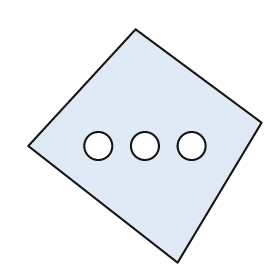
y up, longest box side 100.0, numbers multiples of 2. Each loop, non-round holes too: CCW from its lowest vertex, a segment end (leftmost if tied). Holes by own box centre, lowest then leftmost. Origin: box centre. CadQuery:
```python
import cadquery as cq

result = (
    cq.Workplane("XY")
    .moveTo(14.0, -50.0)
    .lineTo(50.0, 10.0)
    .lineTo(-4.0, 50.0)
    .lineTo(-50.0, 0.0)
    .close()
    .moveTo(-20.0, 0.0)
    .circle(6.0)
    .moveTo(0.0, 0.0)
    .circle(6.0)
    .moveTo(20.0, 0.0)
    .circle(6.0)
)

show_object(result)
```